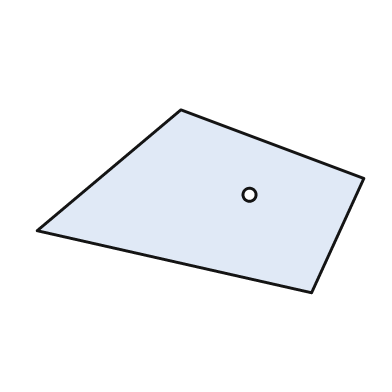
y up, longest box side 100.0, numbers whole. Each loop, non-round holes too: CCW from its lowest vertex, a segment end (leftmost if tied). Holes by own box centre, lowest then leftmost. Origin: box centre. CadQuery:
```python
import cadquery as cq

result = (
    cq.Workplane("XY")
    .moveTo(34.0, -28.0)
    .lineTo(50.0, 7.0)
    .lineTo(-6.0, 28.0)
    .lineTo(-50.0, -9.0)
    .close()
    .moveTo(15.0, 2.0)
    .circle(2.0)
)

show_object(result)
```